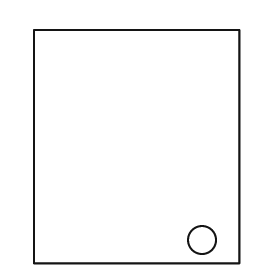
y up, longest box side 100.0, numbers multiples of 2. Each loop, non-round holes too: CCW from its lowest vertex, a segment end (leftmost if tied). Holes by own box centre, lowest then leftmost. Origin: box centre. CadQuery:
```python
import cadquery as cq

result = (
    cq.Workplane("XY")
    .moveTo(-44.0, -50.0)
    .lineTo(44.0, -50.0)
    .lineTo(44.0, 50.0)
    .lineTo(-44.0, 50.0)
    .close()
    .moveTo(28.0, -40.0)
    .circle(6.0)
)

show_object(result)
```